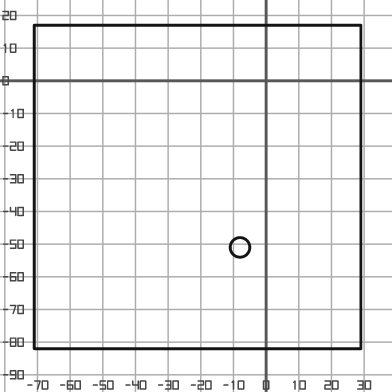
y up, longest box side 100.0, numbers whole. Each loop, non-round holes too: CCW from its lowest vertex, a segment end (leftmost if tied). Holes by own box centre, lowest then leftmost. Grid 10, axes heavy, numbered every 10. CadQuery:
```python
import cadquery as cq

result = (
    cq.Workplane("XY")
    .moveTo(-71.0, -82.0)
    .lineTo(29.0, -82.0)
    .lineTo(29.0, 17.0)
    .lineTo(-71.0, 17.0)
    .close()
    .moveTo(-8.0, -51.0)
    .circle(3.0)
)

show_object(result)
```